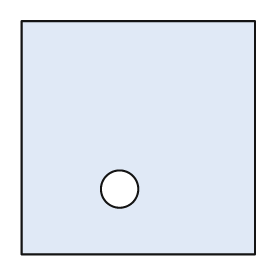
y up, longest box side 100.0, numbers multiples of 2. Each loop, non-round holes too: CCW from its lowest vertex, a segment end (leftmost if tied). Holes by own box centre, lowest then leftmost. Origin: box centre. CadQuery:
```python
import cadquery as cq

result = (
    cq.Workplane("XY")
    .moveTo(-50.0, -50.0)
    .lineTo(50.0, -50.0)
    .lineTo(50.0, 50.0)
    .lineTo(-50.0, 50.0)
    .close()
    .moveTo(-8.0, -22.0)
    .circle(8.0)
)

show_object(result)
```